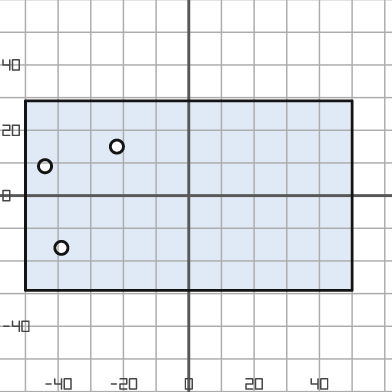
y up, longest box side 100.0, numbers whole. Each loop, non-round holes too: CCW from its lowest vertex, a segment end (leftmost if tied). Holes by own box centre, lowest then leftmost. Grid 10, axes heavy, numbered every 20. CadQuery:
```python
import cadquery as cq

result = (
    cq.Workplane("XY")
    .moveTo(-50.0, -29.0)
    .lineTo(50.0, -29.0)
    .lineTo(50.0, 29.0)
    .lineTo(-50.0, 29.0)
    .close()
    .moveTo(-39.0, -16.0)
    .circle(2.0)
    .moveTo(-44.0, 9.0)
    .circle(2.0)
    .moveTo(-22.0, 15.0)
    .circle(2.0)
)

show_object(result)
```